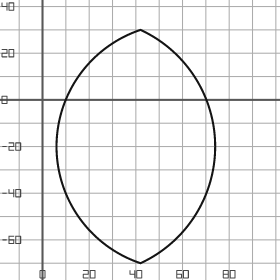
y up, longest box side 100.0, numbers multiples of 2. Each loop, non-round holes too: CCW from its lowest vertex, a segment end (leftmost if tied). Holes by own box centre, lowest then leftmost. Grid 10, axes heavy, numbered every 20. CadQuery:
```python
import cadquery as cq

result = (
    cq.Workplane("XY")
    .moveTo(42.0, -70.0)
    .threePointArc((74.0, -20.0), (42.0, 30.0))
    .threePointArc((6.0, -20.0), (42.0, -70.0))
    .close()
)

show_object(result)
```